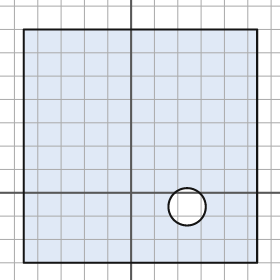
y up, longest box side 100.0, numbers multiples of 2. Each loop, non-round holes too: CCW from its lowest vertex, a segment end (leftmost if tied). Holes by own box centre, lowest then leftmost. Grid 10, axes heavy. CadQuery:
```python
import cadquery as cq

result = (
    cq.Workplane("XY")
    .moveTo(-46.0, -30.0)
    .lineTo(54.0, -30.0)
    .lineTo(54.0, 70.0)
    .lineTo(-46.0, 70.0)
    .close()
    .moveTo(24.0, -6.0)
    .circle(8.0)
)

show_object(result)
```